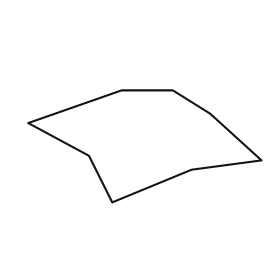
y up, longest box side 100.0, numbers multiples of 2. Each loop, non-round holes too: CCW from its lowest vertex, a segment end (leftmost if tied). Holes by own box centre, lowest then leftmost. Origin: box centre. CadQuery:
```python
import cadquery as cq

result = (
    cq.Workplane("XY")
    .moveTo(-14.0, -24.0)
    .lineTo(20.0, -10.0)
    .lineTo(50.0, -6.0)
    .lineTo(28.0, 14.0)
    .lineTo(12.0, 24.0)
    .lineTo(-10.0, 24.0)
    .lineTo(-50.0, 10.0)
    .lineTo(-24.0, -4.0)
    .close()
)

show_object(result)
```